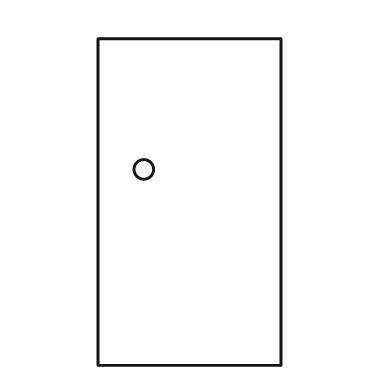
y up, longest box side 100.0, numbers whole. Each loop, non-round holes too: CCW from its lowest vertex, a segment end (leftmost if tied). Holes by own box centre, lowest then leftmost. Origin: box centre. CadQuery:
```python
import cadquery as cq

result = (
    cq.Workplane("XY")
    .moveTo(-28.0, -50.0)
    .lineTo(28.0, -50.0)
    .lineTo(28.0, 50.0)
    .lineTo(-28.0, 50.0)
    .close()
    .moveTo(-14.0, 10.0)
    .circle(3.0)
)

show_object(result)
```